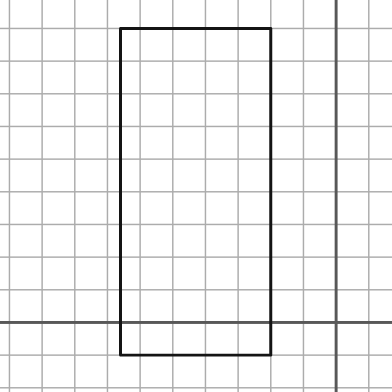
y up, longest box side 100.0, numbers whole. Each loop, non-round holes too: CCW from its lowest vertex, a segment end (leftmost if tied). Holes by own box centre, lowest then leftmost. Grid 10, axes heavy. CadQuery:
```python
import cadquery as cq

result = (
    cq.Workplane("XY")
    .moveTo(-66.0, -10.0)
    .lineTo(-20.0, -10.0)
    .lineTo(-20.0, 90.0)
    .lineTo(-66.0, 90.0)
    .close()
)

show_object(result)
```